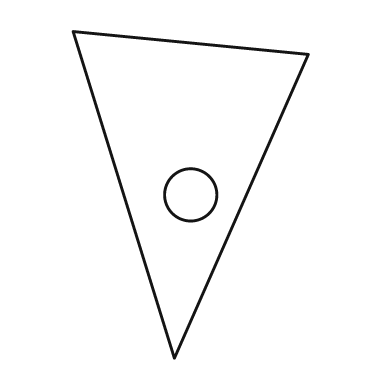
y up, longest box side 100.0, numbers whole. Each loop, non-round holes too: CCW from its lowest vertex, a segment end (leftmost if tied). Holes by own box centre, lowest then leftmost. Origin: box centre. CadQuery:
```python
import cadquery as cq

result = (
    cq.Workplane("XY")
    .moveTo(-5.0, -50.0)
    .lineTo(36.0, 43.0)
    .lineTo(-36.0, 50.0)
    .close()
    .moveTo(0.0, 0.0)
    .circle(8.0)
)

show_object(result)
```